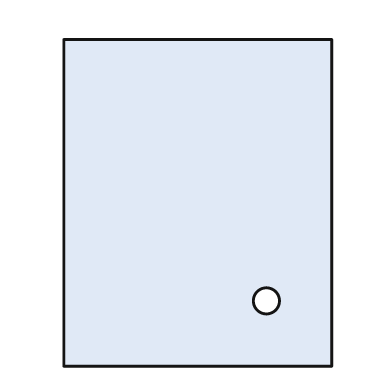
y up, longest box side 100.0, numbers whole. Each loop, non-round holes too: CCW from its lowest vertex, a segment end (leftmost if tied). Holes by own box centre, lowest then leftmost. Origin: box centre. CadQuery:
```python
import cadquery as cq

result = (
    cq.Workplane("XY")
    .moveTo(-41.0, -50.0)
    .lineTo(41.0, -50.0)
    .lineTo(41.0, 50.0)
    .lineTo(-41.0, 50.0)
    .close()
    .moveTo(21.0, -30.0)
    .circle(4.0)
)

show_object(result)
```